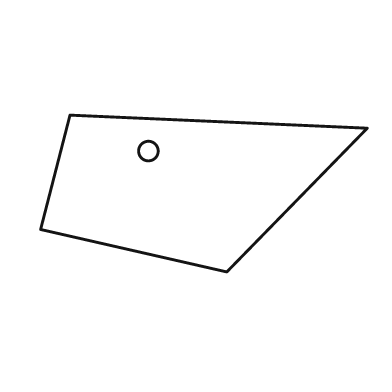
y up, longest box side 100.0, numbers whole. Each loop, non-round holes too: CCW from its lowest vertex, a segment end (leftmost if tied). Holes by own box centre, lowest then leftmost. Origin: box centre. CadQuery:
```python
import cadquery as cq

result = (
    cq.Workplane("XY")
    .moveTo(7.0, -24.0)
    .lineTo(50.0, 20.0)
    .lineTo(-41.0, 24.0)
    .lineTo(-50.0, -11.0)
    .close()
    .moveTo(-17.0, 13.0)
    .circle(3.0)
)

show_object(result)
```